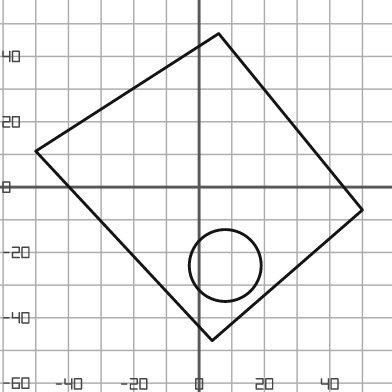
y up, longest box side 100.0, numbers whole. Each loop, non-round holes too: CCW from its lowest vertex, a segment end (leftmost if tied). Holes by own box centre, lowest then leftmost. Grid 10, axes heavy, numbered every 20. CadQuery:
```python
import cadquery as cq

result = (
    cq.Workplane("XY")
    .moveTo(4.0, -47.0)
    .lineTo(50.0, -7.0)
    .lineTo(6.0, 47.0)
    .lineTo(-50.0, 11.0)
    .close()
    .moveTo(8.0, -24.0)
    .circle(11.0)
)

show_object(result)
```